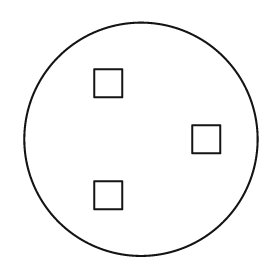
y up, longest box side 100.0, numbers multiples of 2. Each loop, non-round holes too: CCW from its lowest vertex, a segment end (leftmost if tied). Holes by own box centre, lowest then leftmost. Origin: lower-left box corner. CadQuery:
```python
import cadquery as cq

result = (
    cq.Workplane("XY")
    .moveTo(50.0, 50.0)
    .circle(50.0)
    .moveTo(30.0, 20.0)
    .lineTo(42.0, 20.0)
    .lineTo(42.0, 32.0)
    .lineTo(30.0, 32.0)
    .close()
    .moveTo(72.0, 44.0)
    .lineTo(84.0, 44.0)
    .lineTo(84.0, 56.0)
    .lineTo(72.0, 56.0)
    .close()
    .moveTo(30.0, 68.0)
    .lineTo(42.0, 68.0)
    .lineTo(42.0, 80.0)
    .lineTo(30.0, 80.0)
    .close()
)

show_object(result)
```